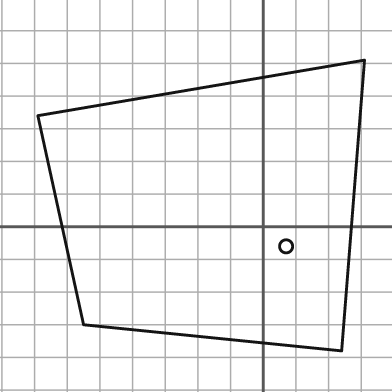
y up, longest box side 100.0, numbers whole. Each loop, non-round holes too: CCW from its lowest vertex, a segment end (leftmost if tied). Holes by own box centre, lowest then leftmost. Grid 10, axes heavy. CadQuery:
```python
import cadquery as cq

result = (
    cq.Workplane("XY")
    .moveTo(24.0, -38.0)
    .lineTo(31.0, 51.0)
    .lineTo(-69.0, 34.0)
    .lineTo(-55.0, -30.0)
    .close()
    .moveTo(7.0, -6.0)
    .circle(2.0)
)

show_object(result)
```